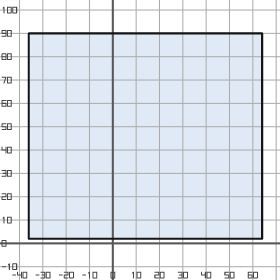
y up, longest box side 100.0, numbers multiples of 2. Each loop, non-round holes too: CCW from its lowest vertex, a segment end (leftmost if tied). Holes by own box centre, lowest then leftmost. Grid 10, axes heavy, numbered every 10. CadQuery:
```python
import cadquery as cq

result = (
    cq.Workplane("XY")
    .moveTo(-36.0, 2.0)
    .lineTo(64.0, 2.0)
    .lineTo(64.0, 90.0)
    .lineTo(-36.0, 90.0)
    .close()
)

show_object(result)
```